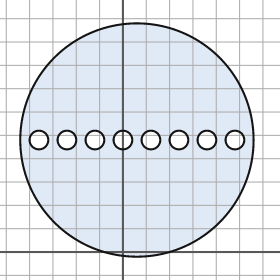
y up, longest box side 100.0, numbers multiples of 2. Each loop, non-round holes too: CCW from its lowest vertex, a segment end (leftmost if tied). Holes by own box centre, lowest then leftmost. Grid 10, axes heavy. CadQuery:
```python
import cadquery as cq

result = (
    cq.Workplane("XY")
    .moveTo(6.0, 48.0)
    .circle(50.0)
    .moveTo(-36.0, 48.0)
    .circle(4.0)
    .moveTo(-24.0, 48.0)
    .circle(4.0)
    .moveTo(-12.0, 48.0)
    .circle(4.0)
    .moveTo(0.0, 48.0)
    .circle(4.0)
    .moveTo(12.0, 48.0)
    .circle(4.0)
    .moveTo(24.0, 48.0)
    .circle(4.0)
    .moveTo(36.0, 48.0)
    .circle(4.0)
    .moveTo(48.0, 48.0)
    .circle(4.0)
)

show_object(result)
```